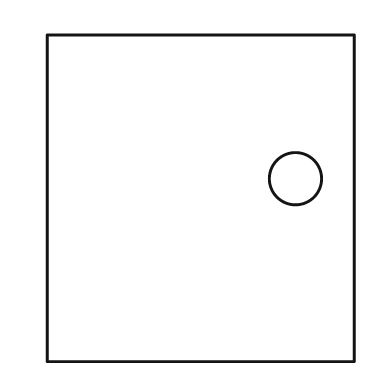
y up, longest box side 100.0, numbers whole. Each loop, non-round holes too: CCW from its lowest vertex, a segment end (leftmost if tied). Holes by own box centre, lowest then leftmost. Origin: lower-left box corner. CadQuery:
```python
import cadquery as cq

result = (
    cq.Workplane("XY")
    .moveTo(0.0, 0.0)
    .lineTo(94.0, 0.0)
    .lineTo(94.0, 100.0)
    .lineTo(0.0, 100.0)
    .close()
    .moveTo(76.0, 56.0)
    .circle(8.0)
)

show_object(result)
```